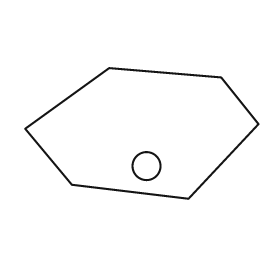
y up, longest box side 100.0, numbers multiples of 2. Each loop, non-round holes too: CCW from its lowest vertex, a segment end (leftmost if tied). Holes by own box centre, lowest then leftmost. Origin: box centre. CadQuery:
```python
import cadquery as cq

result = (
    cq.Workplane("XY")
    .moveTo(20.0, -28.0)
    .lineTo(50.0, 4.0)
    .lineTo(34.0, 24.0)
    .lineTo(-14.0, 28.0)
    .lineTo(-50.0, 2.0)
    .lineTo(-30.0, -22.0)
    .close()
    .moveTo(2.0, -14.0)
    .circle(6.0)
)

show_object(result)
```